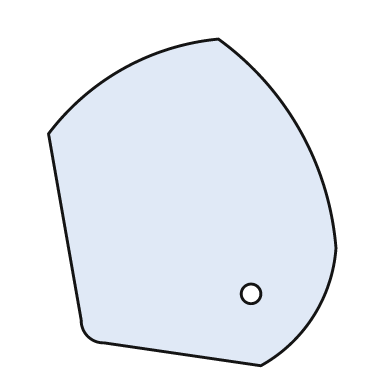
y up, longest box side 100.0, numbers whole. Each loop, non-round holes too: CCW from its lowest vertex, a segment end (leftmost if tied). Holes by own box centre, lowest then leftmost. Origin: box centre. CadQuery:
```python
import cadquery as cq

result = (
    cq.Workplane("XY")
    .moveTo(21.0, -50.0)
    .threePointArc((37.0, -35.0), (44.0, -14.0))
    .threePointArc((33.0, 22.0), (8.0, 50.0))
    .threePointArc((-21.0, 41.0), (-44.0, 21.0))
    .lineTo(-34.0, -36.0)
    .threePointArc((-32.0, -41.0), (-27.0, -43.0))
    .close()
    .moveTo(18.0, -28.0)
    .circle(3.0)
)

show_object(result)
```